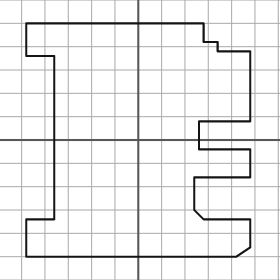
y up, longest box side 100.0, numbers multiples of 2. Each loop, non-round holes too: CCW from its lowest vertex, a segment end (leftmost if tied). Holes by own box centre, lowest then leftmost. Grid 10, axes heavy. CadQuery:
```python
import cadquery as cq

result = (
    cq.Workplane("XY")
    .moveTo(-48.0, -50.0)
    .lineTo(42.0, -50.0)
    .lineTo(48.0, -46.0)
    .lineTo(48.0, -34.0)
    .lineTo(28.0, -34.0)
    .lineTo(24.0, -30.0)
    .lineTo(24.0, -16.0)
    .lineTo(48.0, -16.0)
    .lineTo(48.0, -4.0)
    .lineTo(26.0, -4.0)
    .lineTo(26.0, 8.0)
    .lineTo(48.0, 8.0)
    .lineTo(48.0, 38.0)
    .lineTo(34.0, 38.0)
    .lineTo(34.0, 42.0)
    .lineTo(28.0, 42.0)
    .lineTo(28.0, 50.0)
    .lineTo(-48.0, 50.0)
    .lineTo(-48.0, 36.0)
    .lineTo(-36.0, 36.0)
    .lineTo(-36.0, -34.0)
    .lineTo(-48.0, -34.0)
    .close()
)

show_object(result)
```